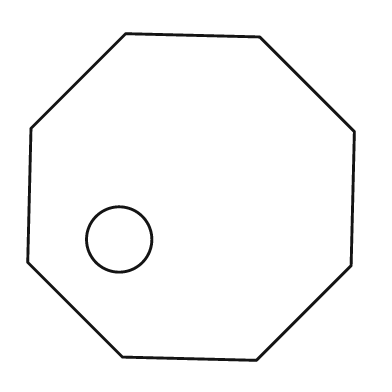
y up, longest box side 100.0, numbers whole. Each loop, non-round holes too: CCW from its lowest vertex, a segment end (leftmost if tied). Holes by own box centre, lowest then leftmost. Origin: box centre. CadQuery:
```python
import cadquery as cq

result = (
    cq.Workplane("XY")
    .moveTo(20.0, -50.0)
    .lineTo(49.0, -21.0)
    .lineTo(50.0, 20.0)
    .lineTo(21.0, 49.0)
    .lineTo(-20.0, 50.0)
    .lineTo(-49.0, 21.0)
    .lineTo(-50.0, -20.0)
    .lineTo(-21.0, -49.0)
    .close()
    .moveTo(-22.0, -13.0)
    .circle(10.0)
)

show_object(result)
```